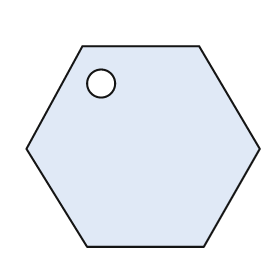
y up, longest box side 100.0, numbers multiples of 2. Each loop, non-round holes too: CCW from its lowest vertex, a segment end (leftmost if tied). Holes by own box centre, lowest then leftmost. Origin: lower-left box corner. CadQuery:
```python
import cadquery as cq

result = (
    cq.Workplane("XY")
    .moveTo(26.0, 0.0)
    .lineTo(76.0, 0.0)
    .lineTo(100.0, 42.0)
    .lineTo(74.0, 86.0)
    .lineTo(24.0, 86.0)
    .lineTo(0.0, 42.0)
    .close()
    .moveTo(32.0, 70.0)
    .circle(6.0)
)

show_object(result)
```